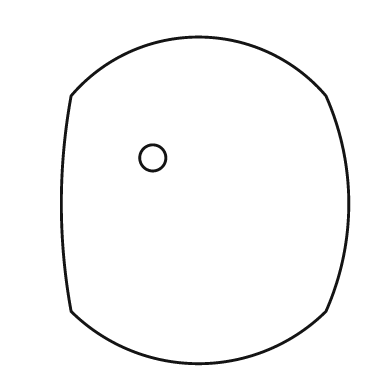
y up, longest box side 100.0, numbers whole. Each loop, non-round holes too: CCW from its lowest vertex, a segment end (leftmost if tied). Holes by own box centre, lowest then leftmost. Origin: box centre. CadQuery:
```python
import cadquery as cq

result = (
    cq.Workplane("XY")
    .moveTo(-41.0, -34.0)
    .threePointArc((-2.0, -50.0), (37.0, -34.0))
    .threePointArc((44.0, -1.0), (37.0, 32.0))
    .threePointArc((-2.0, 50.0), (-41.0, 32.0))
    .threePointArc((-44.0, -1.0), (-41.0, -34.0))
    .close()
    .moveTo(-16.0, 13.0)
    .circle(4.0)
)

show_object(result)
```